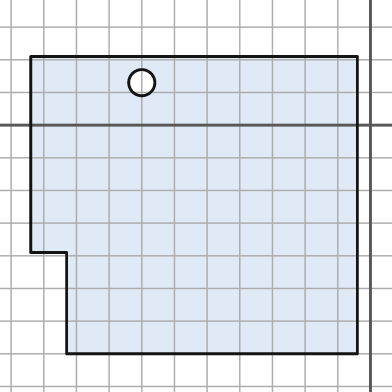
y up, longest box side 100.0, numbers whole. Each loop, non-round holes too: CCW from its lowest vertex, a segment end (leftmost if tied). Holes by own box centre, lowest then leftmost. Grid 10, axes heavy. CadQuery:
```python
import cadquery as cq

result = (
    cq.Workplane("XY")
    .moveTo(-93.0, -70.0)
    .lineTo(-4.0, -70.0)
    .lineTo(-4.0, 21.0)
    .lineTo(-104.0, 21.0)
    .lineTo(-104.0, -39.0)
    .lineTo(-93.0, -39.0)
    .close()
    .moveTo(-70.0, 13.0)
    .circle(4.0)
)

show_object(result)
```